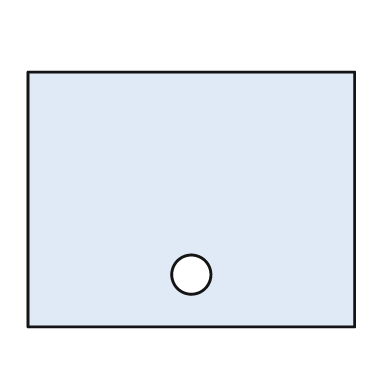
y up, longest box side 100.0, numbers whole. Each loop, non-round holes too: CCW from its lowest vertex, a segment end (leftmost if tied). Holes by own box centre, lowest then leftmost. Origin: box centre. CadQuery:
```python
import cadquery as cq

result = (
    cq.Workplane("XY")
    .moveTo(-50.0, -39.0)
    .lineTo(50.0, -39.0)
    .lineTo(50.0, 39.0)
    .lineTo(-50.0, 39.0)
    .close()
    .moveTo(0.0, -23.0)
    .circle(6.0)
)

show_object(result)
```